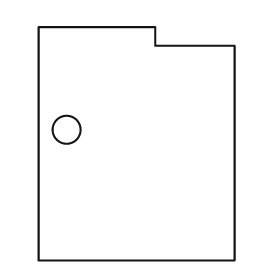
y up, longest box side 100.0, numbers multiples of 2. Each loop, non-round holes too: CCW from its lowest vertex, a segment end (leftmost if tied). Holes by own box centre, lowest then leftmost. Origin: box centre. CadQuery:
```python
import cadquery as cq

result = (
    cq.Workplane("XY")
    .moveTo(-42.0, -50.0)
    .lineTo(42.0, -50.0)
    .lineTo(42.0, 42.0)
    .lineTo(8.0, 42.0)
    .lineTo(8.0, 50.0)
    .lineTo(-42.0, 50.0)
    .close()
    .moveTo(-30.0, 6.0)
    .circle(6.0)
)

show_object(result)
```